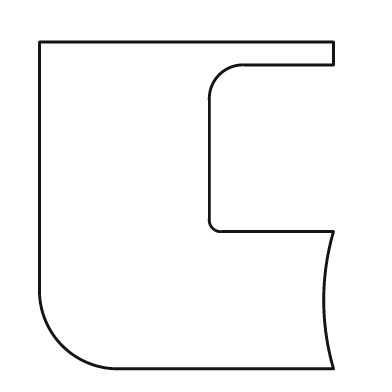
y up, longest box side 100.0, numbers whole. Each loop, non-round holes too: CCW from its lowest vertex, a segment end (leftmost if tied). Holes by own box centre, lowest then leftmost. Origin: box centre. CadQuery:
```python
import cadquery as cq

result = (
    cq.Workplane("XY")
    .moveTo(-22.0, -50.0)
    .lineTo(45.0, -50.0)
    .threePointArc((42.0, -29.0), (45.0, -8.0))
    .lineTo(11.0, -8.0)
    .threePointArc((8.0, -7.0), (7.0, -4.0))
    .lineTo(7.0, 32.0)
    .threePointArc((10.0, 40.0), (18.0, 43.0))
    .lineTo(45.0, 43.0)
    .lineTo(45.0, 50.0)
    .lineTo(-45.0, 50.0)
    .lineTo(-45.0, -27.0)
    .threePointArc((-38.0, -43.0), (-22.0, -50.0))
    .close()
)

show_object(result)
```